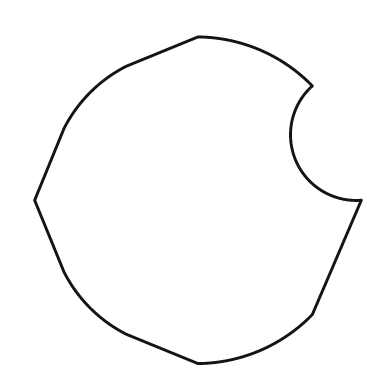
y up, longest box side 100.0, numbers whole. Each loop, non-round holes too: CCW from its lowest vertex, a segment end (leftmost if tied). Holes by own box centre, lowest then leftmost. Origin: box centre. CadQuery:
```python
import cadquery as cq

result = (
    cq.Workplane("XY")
    .moveTo(0.0, -50.0)
    .threePointArc((19.0, -46.0), (35.0, -35.0))
    .lineTo(50.0, 0.0)
    .threePointArc((30.0, 12.0), (35.0, 35.0))
    .threePointArc((19.0, 46.0), (0.0, 50.0))
    .lineTo(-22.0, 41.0)
    .threePointArc((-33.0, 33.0), (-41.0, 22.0))
    .lineTo(-50.0, 0.0)
    .lineTo(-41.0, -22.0)
    .threePointArc((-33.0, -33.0), (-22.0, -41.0))
    .close()
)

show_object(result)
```